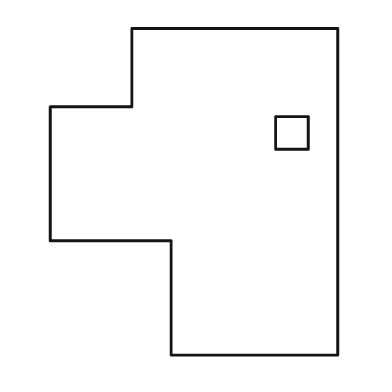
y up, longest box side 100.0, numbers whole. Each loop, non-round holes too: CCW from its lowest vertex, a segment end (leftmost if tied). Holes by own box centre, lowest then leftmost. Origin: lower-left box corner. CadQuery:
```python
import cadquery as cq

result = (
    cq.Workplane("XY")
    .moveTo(37.0, 0.0)
    .lineTo(88.0, 0.0)
    .lineTo(88.0, 100.0)
    .lineTo(25.0, 100.0)
    .lineTo(25.0, 76.0)
    .lineTo(0.0, 76.0)
    .lineTo(0.0, 35.0)
    .lineTo(37.0, 35.0)
    .close()
    .moveTo(69.0, 63.0)
    .lineTo(79.0, 63.0)
    .lineTo(79.0, 73.0)
    .lineTo(69.0, 73.0)
    .close()
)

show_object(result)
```